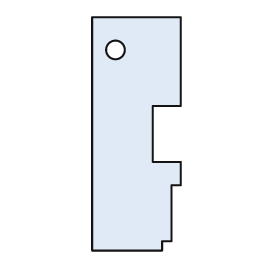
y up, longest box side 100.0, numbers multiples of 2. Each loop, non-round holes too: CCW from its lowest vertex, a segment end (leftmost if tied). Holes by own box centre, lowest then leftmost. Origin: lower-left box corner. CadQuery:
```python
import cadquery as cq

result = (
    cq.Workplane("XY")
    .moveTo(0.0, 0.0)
    .lineTo(30.0, 0.0)
    .lineTo(30.0, 4.0)
    .lineTo(34.0, 4.0)
    .lineTo(34.0, 28.0)
    .lineTo(38.0, 28.0)
    .lineTo(38.0, 38.0)
    .lineTo(26.0, 38.0)
    .lineTo(26.0, 62.0)
    .lineTo(38.0, 62.0)
    .lineTo(38.0, 100.0)
    .lineTo(0.0, 100.0)
    .close()
    .moveTo(10.0, 86.0)
    .circle(4.0)
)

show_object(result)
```